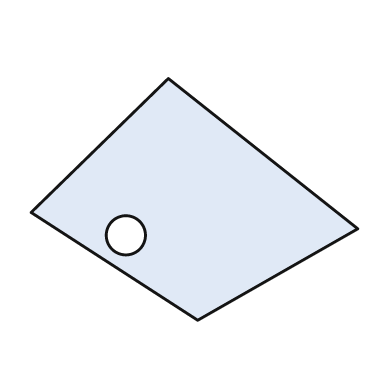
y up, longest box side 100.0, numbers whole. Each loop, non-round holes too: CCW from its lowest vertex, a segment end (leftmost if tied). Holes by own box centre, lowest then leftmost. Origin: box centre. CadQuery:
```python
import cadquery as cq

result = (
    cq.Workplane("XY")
    .moveTo(1.0, -37.0)
    .lineTo(50.0, -9.0)
    .lineTo(-8.0, 37.0)
    .lineTo(-50.0, -4.0)
    .close()
    .moveTo(-21.0, -11.0)
    .circle(6.0)
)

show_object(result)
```